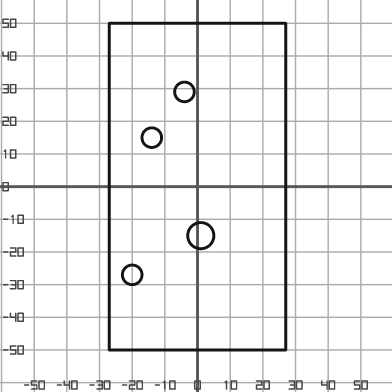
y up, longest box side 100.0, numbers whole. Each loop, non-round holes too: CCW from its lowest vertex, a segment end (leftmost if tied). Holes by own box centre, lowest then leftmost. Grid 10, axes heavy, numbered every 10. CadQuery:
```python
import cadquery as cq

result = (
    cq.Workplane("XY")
    .moveTo(-27.0, -50.0)
    .lineTo(27.0, -50.0)
    .lineTo(27.0, 50.0)
    .lineTo(-27.0, 50.0)
    .close()
    .moveTo(-20.0, -27.0)
    .circle(3.0)
    .moveTo(1.0, -15.0)
    .circle(4.0)
    .moveTo(-14.0, 15.0)
    .circle(3.0)
    .moveTo(-4.0, 29.0)
    .circle(3.0)
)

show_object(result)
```